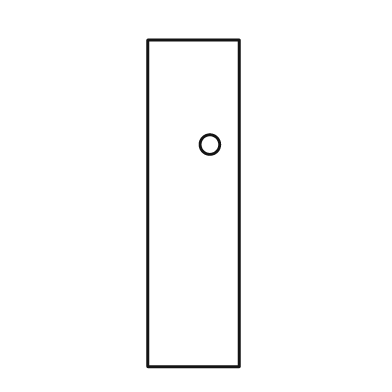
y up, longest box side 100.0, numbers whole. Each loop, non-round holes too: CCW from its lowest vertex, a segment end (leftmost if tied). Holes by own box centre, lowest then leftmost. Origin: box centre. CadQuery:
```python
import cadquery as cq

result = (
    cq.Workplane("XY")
    .moveTo(-14.0, -50.0)
    .lineTo(14.0, -50.0)
    .lineTo(14.0, 50.0)
    .lineTo(-14.0, 50.0)
    .close()
    .moveTo(5.0, 18.0)
    .circle(3.0)
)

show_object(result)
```